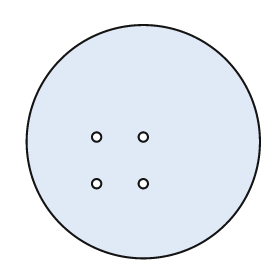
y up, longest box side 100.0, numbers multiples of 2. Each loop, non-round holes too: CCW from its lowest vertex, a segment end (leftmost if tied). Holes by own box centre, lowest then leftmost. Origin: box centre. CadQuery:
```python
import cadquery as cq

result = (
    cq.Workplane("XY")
    .moveTo(0.0, 0.0)
    .circle(50.0)
    .moveTo(-20.0, -18.0)
    .circle(2.0)
    .moveTo(0.0, -18.0)
    .circle(2.0)
    .moveTo(-20.0, 2.0)
    .circle(2.0)
    .moveTo(0.0, 2.0)
    .circle(2.0)
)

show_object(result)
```